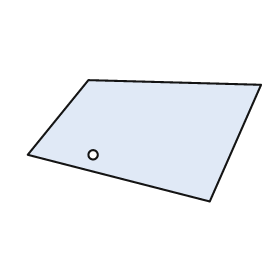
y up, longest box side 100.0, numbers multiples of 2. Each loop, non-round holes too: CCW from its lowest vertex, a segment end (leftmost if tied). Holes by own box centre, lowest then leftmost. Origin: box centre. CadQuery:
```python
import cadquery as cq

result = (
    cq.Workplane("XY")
    .moveTo(28.0, -26.0)
    .lineTo(50.0, 24.0)
    .lineTo(-24.0, 26.0)
    .lineTo(-50.0, -6.0)
    .close()
    .moveTo(-22.0, -6.0)
    .circle(2.0)
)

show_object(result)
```